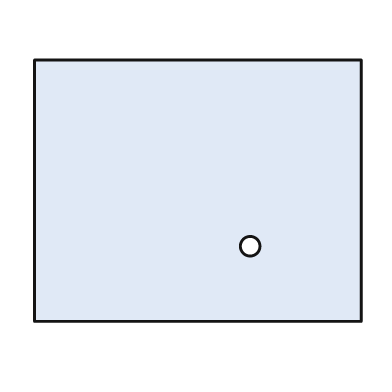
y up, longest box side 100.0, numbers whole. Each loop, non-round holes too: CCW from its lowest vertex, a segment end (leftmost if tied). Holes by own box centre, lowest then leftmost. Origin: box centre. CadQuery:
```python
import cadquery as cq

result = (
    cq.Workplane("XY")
    .moveTo(-50.0, -40.0)
    .lineTo(50.0, -40.0)
    .lineTo(50.0, 40.0)
    .lineTo(-50.0, 40.0)
    .close()
    .moveTo(16.0, -17.0)
    .circle(3.0)
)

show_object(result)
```